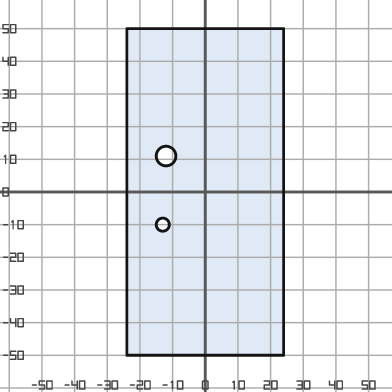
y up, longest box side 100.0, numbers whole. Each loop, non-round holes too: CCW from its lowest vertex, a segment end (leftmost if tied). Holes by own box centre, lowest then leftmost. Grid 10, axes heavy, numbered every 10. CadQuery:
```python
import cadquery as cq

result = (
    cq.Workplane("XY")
    .moveTo(-24.0, -50.0)
    .lineTo(24.0, -50.0)
    .lineTo(24.0, 50.0)
    .lineTo(-24.0, 50.0)
    .close()
    .moveTo(-13.0, -10.0)
    .circle(2.0)
    .moveTo(-12.0, 11.0)
    .circle(3.0)
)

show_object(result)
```